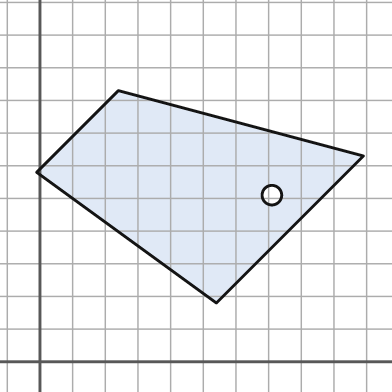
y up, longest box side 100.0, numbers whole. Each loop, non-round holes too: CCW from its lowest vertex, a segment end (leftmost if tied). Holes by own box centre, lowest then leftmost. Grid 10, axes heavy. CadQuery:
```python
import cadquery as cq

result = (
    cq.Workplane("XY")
    .moveTo(54.0, 18.0)
    .lineTo(99.0, 63.0)
    .lineTo(24.0, 83.0)
    .lineTo(-1.0, 58.0)
    .close()
    .moveTo(71.0, 51.0)
    .circle(3.0)
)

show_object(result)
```